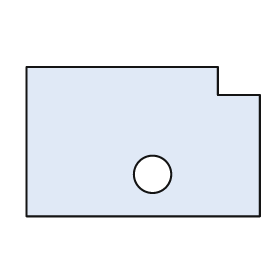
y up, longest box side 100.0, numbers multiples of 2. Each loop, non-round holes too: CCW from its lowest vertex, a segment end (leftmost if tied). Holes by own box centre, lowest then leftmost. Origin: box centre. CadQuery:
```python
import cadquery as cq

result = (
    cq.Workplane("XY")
    .moveTo(-50.0, -32.0)
    .lineTo(50.0, -32.0)
    .lineTo(50.0, 20.0)
    .lineTo(32.0, 20.0)
    .lineTo(32.0, 32.0)
    .lineTo(-50.0, 32.0)
    .close()
    .moveTo(4.0, -14.0)
    .circle(8.0)
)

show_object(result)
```